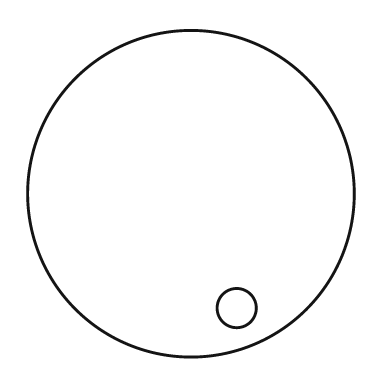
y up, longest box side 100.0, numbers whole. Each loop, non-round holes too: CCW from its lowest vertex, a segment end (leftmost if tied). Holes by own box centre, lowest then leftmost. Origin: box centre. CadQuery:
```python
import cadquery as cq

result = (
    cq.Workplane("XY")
    .moveTo(0.0, 0.0)
    .circle(50.0)
    .moveTo(14.0, -35.0)
    .circle(6.0)
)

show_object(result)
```